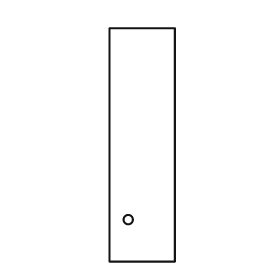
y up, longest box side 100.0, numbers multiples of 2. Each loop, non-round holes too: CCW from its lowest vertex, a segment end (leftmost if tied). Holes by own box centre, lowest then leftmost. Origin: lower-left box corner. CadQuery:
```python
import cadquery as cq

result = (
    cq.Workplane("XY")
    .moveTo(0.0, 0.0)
    .lineTo(28.0, 0.0)
    .lineTo(28.0, 100.0)
    .lineTo(0.0, 100.0)
    .close()
    .moveTo(8.0, 18.0)
    .circle(2.0)
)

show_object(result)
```